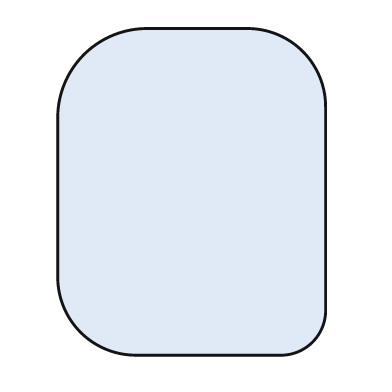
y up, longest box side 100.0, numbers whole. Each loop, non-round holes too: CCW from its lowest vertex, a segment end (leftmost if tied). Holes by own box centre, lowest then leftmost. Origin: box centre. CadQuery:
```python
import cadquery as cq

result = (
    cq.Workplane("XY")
    .moveTo(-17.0, -50.0)
    .lineTo(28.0, -50.0)
    .threePointArc((37.0, -46.0), (41.0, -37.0))
    .lineTo(41.0, 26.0)
    .threePointArc((34.0, 43.0), (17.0, 50.0))
    .lineTo(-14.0, 50.0)
    .threePointArc((-33.0, 42.0), (-41.0, 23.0))
    .lineTo(-41.0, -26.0)
    .threePointArc((-34.0, -43.0), (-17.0, -50.0))
    .close()
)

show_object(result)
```